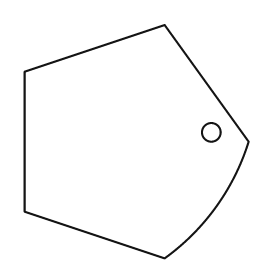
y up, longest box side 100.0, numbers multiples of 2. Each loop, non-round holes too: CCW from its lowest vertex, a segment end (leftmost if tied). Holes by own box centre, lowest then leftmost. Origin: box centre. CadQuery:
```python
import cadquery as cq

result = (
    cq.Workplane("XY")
    .moveTo(12.0, -50.0)
    .threePointArc((34.0, -28.0), (48.0, 0.0))
    .lineTo(12.0, 50.0)
    .lineTo(-48.0, 30.0)
    .lineTo(-48.0, -30.0)
    .close()
    .moveTo(32.0, 4.0)
    .circle(4.0)
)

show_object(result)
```